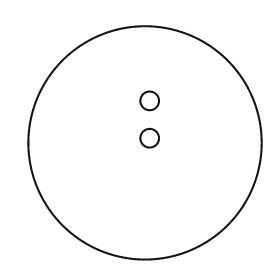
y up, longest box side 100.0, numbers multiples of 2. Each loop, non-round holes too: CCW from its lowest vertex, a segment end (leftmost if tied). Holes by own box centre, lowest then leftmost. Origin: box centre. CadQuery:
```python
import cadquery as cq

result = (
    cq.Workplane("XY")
    .moveTo(0.0, 0.0)
    .circle(50.0)
    .moveTo(2.0, 2.0)
    .circle(4.0)
    .moveTo(2.0, 18.0)
    .circle(4.0)
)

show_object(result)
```